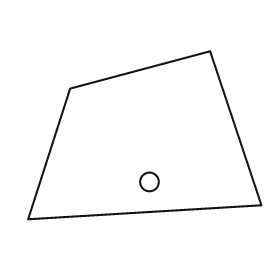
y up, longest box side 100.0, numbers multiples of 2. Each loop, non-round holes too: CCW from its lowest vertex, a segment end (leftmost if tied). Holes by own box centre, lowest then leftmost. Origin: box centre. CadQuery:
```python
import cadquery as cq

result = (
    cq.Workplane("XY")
    .moveTo(-50.0, -36.0)
    .lineTo(50.0, -30.0)
    .lineTo(28.0, 36.0)
    .lineTo(-32.0, 20.0)
    .close()
    .moveTo(2.0, -20.0)
    .circle(4.0)
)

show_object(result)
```